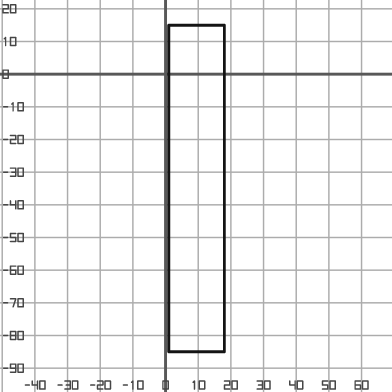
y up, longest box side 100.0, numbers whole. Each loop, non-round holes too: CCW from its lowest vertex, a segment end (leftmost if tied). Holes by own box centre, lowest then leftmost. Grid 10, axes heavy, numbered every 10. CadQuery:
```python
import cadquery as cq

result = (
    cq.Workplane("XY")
    .moveTo(1.0, -85.0)
    .lineTo(18.0, -85.0)
    .lineTo(18.0, 15.0)
    .lineTo(1.0, 15.0)
    .close()
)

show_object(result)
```